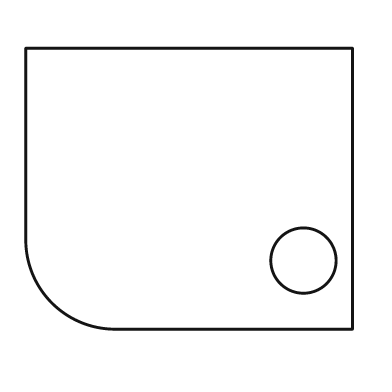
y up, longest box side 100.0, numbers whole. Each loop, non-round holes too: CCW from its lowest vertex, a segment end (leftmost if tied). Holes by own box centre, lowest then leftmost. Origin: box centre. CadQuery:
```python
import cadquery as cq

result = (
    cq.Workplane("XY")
    .moveTo(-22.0, -43.0)
    .lineTo(50.0, -43.0)
    .lineTo(50.0, 43.0)
    .lineTo(-50.0, 43.0)
    .lineTo(-50.0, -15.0)
    .threePointArc((-42.0, -35.0), (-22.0, -43.0))
    .close()
    .moveTo(35.0, -22.0)
    .circle(10.0)
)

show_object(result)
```